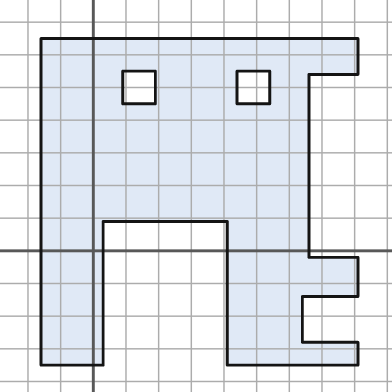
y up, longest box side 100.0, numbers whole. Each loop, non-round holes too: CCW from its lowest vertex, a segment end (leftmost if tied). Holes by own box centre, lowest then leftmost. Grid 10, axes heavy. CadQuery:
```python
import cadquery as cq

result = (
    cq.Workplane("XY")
    .moveTo(-16.0, -35.0)
    .lineTo(3.0, -35.0)
    .lineTo(3.0, 9.0)
    .lineTo(41.0, 9.0)
    .lineTo(41.0, -35.0)
    .lineTo(81.0, -35.0)
    .lineTo(81.0, -28.0)
    .lineTo(64.0, -28.0)
    .lineTo(64.0, -14.0)
    .lineTo(81.0, -14.0)
    .lineTo(81.0, -2.0)
    .lineTo(66.0, -2.0)
    .lineTo(66.0, 54.0)
    .lineTo(81.0, 54.0)
    .lineTo(81.0, 65.0)
    .lineTo(-16.0, 65.0)
    .close()
    .moveTo(9.0, 45.0)
    .lineTo(19.0, 45.0)
    .lineTo(19.0, 55.0)
    .lineTo(9.0, 55.0)
    .close()
    .moveTo(44.0, 45.0)
    .lineTo(54.0, 45.0)
    .lineTo(54.0, 55.0)
    .lineTo(44.0, 55.0)
    .close()
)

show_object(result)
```